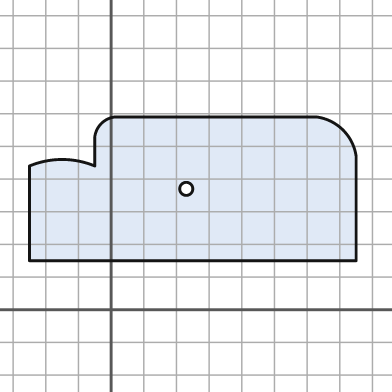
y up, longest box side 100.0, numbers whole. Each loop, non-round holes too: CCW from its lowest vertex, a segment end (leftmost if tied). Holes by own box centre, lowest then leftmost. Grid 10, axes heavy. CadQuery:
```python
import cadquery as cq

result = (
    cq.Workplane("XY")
    .moveTo(-25.0, 15.0)
    .lineTo(75.0, 15.0)
    .lineTo(75.0, 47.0)
    .threePointArc((71.0, 55.0), (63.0, 59.0))
    .lineTo(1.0, 59.0)
    .threePointArc((-3.0, 57.0), (-5.0, 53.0))
    .lineTo(-5.0, 44.0)
    .threePointArc((-15.0, 46.0), (-25.0, 44.0))
    .close()
    .moveTo(23.0, 37.0)
    .circle(2.0)
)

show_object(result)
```